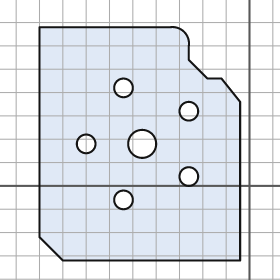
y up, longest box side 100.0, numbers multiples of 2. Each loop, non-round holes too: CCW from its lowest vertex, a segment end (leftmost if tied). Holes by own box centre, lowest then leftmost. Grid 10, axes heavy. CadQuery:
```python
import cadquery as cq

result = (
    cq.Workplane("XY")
    .moveTo(-80.0, -32.0)
    .lineTo(-4.0, -32.0)
    .lineTo(-4.0, 36.0)
    .lineTo(-12.0, 46.0)
    .lineTo(-18.0, 46.0)
    .lineTo(-26.0, 54.0)
    .lineTo(-26.0, 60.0)
    .threePointArc((-28.0, 66.0), (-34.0, 68.0))
    .lineTo(-90.0, 68.0)
    .lineTo(-90.0, -22.0)
    .close()
    .moveTo(-54.0, -6.0)
    .circle(4.0)
    .moveTo(-26.0, 4.0)
    .circle(4.0)
    .moveTo(-70.0, 18.0)
    .circle(4.0)
    .moveTo(-46.0, 18.0)
    .circle(6.0)
    .moveTo(-26.0, 32.0)
    .circle(4.0)
    .moveTo(-54.0, 42.0)
    .circle(4.0)
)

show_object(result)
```